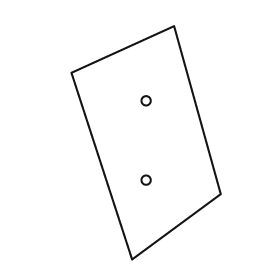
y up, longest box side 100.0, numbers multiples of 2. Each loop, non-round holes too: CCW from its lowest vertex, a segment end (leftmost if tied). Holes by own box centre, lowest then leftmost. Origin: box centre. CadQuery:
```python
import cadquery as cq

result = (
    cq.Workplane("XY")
    .moveTo(-6.0, -50.0)
    .lineTo(32.0, -22.0)
    .lineTo(12.0, 50.0)
    .lineTo(-32.0, 30.0)
    .close()
    .moveTo(0.0, -16.0)
    .circle(2.0)
    .moveTo(0.0, 18.0)
    .circle(2.0)
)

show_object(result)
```